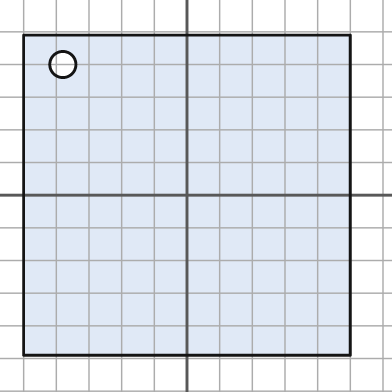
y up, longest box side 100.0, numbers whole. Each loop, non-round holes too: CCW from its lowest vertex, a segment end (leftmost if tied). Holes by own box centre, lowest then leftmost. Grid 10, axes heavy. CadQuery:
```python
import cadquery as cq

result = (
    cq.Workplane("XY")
    .moveTo(-50.0, -49.0)
    .lineTo(50.0, -49.0)
    .lineTo(50.0, 49.0)
    .lineTo(-50.0, 49.0)
    .close()
    .moveTo(-38.0, 40.0)
    .circle(4.0)
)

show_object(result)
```